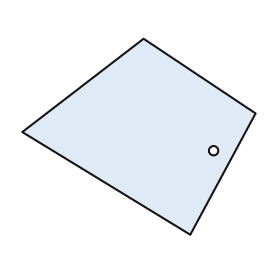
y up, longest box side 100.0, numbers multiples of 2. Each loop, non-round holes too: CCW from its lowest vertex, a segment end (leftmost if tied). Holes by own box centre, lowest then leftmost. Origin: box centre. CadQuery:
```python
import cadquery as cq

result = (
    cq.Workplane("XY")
    .moveTo(22.0, -42.0)
    .lineTo(50.0, 10.0)
    .lineTo(2.0, 42.0)
    .lineTo(-50.0, 2.0)
    .close()
    .moveTo(32.0, -6.0)
    .circle(2.0)
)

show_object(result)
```